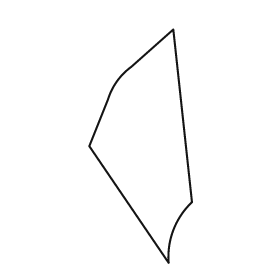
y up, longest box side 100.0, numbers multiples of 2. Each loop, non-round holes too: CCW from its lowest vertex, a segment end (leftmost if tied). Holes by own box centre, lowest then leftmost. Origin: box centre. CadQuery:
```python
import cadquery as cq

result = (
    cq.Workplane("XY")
    .moveTo(12.0, -50.0)
    .threePointArc((14.0, -36.0), (22.0, -24.0))
    .lineTo(14.0, 50.0)
    .lineTo(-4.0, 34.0)
    .threePointArc((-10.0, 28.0), (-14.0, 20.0))
    .lineTo(-22.0, 0.0)
    .close()
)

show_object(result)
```